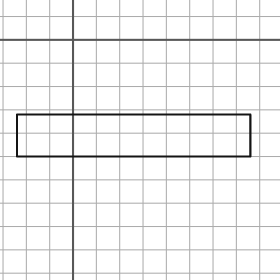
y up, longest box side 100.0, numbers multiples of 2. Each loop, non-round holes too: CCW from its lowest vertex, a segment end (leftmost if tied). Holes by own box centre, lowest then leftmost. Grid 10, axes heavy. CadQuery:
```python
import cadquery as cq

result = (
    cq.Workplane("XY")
    .moveTo(-24.0, -50.0)
    .lineTo(76.0, -50.0)
    .lineTo(76.0, -32.0)
    .lineTo(-24.0, -32.0)
    .close()
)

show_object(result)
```